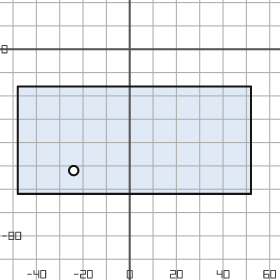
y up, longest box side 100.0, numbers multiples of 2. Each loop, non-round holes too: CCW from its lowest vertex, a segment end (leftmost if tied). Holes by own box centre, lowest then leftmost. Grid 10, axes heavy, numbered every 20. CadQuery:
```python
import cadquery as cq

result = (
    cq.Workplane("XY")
    .moveTo(-48.0, -62.0)
    .lineTo(52.0, -62.0)
    .lineTo(52.0, -16.0)
    .lineTo(-48.0, -16.0)
    .close()
    .moveTo(-24.0, -52.0)
    .circle(2.0)
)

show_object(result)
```